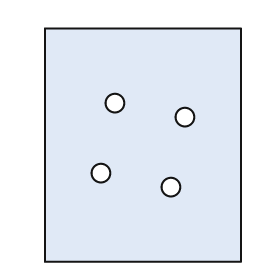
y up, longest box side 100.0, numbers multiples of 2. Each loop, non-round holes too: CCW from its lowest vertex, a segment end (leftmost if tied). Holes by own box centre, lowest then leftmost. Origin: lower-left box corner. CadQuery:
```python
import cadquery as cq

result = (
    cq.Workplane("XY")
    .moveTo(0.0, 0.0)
    .lineTo(84.0, 0.0)
    .lineTo(84.0, 100.0)
    .lineTo(0.0, 100.0)
    .close()
    .moveTo(54.0, 32.0)
    .circle(4.0)
    .moveTo(24.0, 38.0)
    .circle(4.0)
    .moveTo(60.0, 62.0)
    .circle(4.0)
    .moveTo(30.0, 68.0)
    .circle(4.0)
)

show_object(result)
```